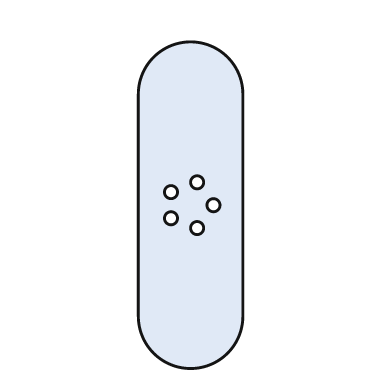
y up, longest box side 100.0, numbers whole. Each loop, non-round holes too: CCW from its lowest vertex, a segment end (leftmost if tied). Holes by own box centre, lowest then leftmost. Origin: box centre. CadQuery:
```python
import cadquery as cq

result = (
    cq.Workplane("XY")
    .moveTo(-16.0, -34.0)
    .threePointArc((0.0, -50.0), (16.0, -34.0))
    .lineTo(16.0, 34.0)
    .threePointArc((0.0, 50.0), (-16.0, 34.0))
    .close()
    .moveTo(2.0, -7.0)
    .circle(2.0)
    .moveTo(-6.0, -4.0)
    .circle(2.0)
    .moveTo(7.0, 0.0)
    .circle(2.0)
    .moveTo(-6.0, 4.0)
    .circle(2.0)
    .moveTo(2.0, 7.0)
    .circle(2.0)
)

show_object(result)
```